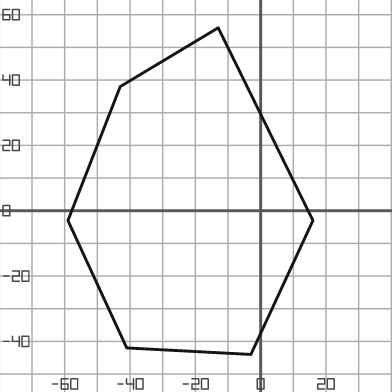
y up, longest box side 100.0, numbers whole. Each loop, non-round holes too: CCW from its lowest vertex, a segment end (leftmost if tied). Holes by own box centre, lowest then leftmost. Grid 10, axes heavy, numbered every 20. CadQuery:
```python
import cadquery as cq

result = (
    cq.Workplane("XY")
    .moveTo(-3.0, -44.0)
    .lineTo(16.0, -3.0)
    .lineTo(-13.0, 56.0)
    .lineTo(-43.0, 38.0)
    .lineTo(-59.0, -3.0)
    .lineTo(-41.0, -42.0)
    .close()
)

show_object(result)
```